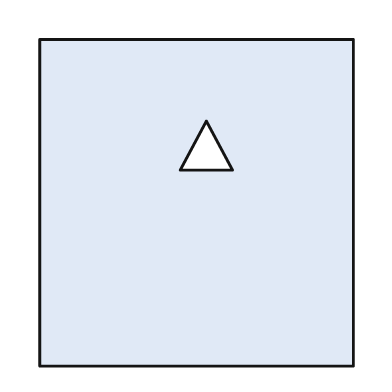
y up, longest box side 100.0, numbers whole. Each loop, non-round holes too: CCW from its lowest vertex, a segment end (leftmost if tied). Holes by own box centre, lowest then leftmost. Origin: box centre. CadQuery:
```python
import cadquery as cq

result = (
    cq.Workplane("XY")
    .moveTo(-48.0, -50.0)
    .lineTo(48.0, -50.0)
    .lineTo(48.0, 50.0)
    .lineTo(-48.0, 50.0)
    .close()
    .moveTo(-5.0, 10.0)
    .lineTo(11.0, 10.0)
    .lineTo(3.0, 25.0)
    .close()
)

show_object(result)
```